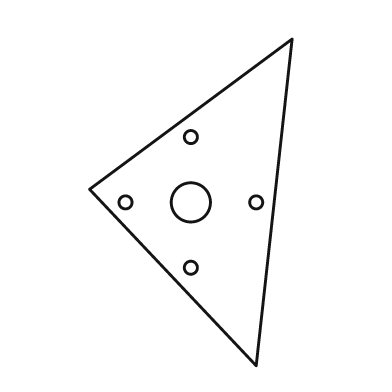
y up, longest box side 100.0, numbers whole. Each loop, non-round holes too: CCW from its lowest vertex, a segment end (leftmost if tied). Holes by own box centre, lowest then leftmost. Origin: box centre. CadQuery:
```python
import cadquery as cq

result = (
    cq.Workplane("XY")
    .moveTo(20.0, -50.0)
    .lineTo(31.0, 50.0)
    .lineTo(-31.0, 4.0)
    .close()
    .moveTo(0.0, -20.0)
    .circle(2.0)
    .moveTo(-20.0, 0.0)
    .circle(2.0)
    .moveTo(0.0, 0.0)
    .circle(6.0)
    .moveTo(20.0, 0.0)
    .circle(2.0)
    .moveTo(0.0, 20.0)
    .circle(2.0)
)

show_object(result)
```